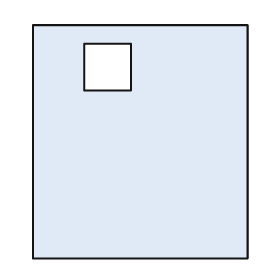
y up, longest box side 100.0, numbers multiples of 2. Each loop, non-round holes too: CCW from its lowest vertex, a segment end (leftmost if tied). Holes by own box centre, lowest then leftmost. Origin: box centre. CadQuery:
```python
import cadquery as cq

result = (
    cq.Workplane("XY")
    .moveTo(-46.0, -50.0)
    .lineTo(46.0, -50.0)
    .lineTo(46.0, 50.0)
    .lineTo(-46.0, 50.0)
    .close()
    .moveTo(-24.0, 22.0)
    .lineTo(-4.0, 22.0)
    .lineTo(-4.0, 42.0)
    .lineTo(-24.0, 42.0)
    .close()
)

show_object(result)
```